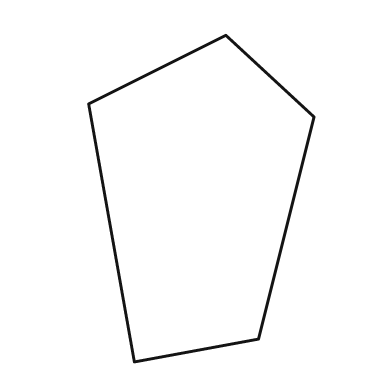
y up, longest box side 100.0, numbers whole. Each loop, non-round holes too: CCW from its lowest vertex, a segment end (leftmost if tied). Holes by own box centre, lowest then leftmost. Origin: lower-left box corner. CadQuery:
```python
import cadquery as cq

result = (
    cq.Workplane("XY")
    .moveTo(14.0, 0.0)
    .lineTo(52.0, 7.0)
    .lineTo(69.0, 75.0)
    .lineTo(42.0, 100.0)
    .lineTo(0.0, 79.0)
    .close()
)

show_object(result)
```